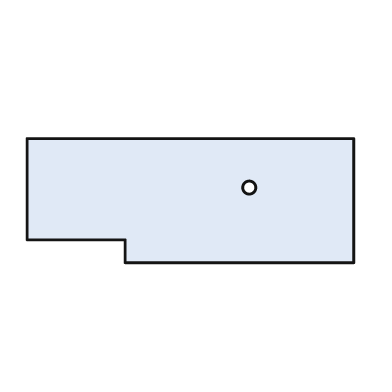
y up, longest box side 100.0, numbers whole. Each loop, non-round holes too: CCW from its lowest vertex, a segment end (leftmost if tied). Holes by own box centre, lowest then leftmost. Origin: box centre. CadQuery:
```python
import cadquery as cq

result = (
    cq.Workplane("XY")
    .moveTo(-20.0, -19.0)
    .lineTo(50.0, -19.0)
    .lineTo(50.0, 19.0)
    .lineTo(-50.0, 19.0)
    .lineTo(-50.0, -12.0)
    .lineTo(-20.0, -12.0)
    .close()
    .moveTo(18.0, 4.0)
    .circle(2.0)
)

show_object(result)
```